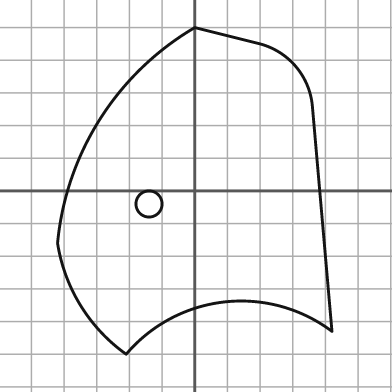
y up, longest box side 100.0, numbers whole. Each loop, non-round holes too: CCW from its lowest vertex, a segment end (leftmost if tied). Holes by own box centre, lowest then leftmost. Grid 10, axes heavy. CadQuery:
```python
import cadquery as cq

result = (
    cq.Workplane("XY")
    .moveTo(-21.0, -50.0)
    .threePointArc((9.0, -34.0), (42.0, -43.0))
    .lineTo(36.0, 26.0)
    .threePointArc((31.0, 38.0), (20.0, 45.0))
    .lineTo(0.0, 50.0)
    .threePointArc((-29.0, 22.0), (-42.0, -16.0))
    .threePointArc((-35.0, -35.0), (-21.0, -50.0))
    .close()
    .moveTo(-14.0, -4.0)
    .circle(4.0)
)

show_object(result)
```